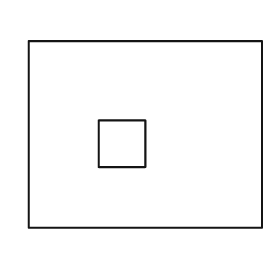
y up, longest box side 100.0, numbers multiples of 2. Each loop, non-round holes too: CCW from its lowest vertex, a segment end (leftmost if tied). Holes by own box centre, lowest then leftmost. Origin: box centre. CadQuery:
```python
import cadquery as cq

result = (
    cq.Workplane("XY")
    .moveTo(-50.0, -40.0)
    .lineTo(50.0, -40.0)
    .lineTo(50.0, 40.0)
    .lineTo(-50.0, 40.0)
    .close()
    .moveTo(-20.0, -14.0)
    .lineTo(0.0, -14.0)
    .lineTo(0.0, 6.0)
    .lineTo(-20.0, 6.0)
    .close()
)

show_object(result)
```